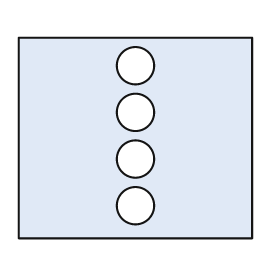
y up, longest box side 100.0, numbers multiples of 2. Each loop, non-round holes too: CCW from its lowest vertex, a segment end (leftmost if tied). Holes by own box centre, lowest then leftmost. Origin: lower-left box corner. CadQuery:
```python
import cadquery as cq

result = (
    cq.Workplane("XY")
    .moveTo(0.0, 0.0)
    .lineTo(100.0, 0.0)
    .lineTo(100.0, 86.0)
    .lineTo(0.0, 86.0)
    .close()
    .moveTo(50.0, 14.0)
    .circle(8.0)
    .moveTo(50.0, 34.0)
    .circle(8.0)
    .moveTo(50.0, 54.0)
    .circle(8.0)
    .moveTo(50.0, 74.0)
    .circle(8.0)
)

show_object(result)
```